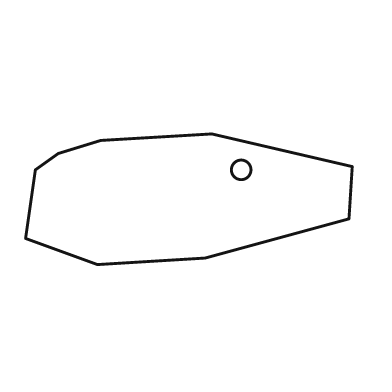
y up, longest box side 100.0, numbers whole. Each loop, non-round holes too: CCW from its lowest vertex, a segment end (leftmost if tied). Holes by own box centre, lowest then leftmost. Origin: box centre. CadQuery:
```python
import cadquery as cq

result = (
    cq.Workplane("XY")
    .moveTo(-28.0, -20.0)
    .lineTo(5.0, -18.0)
    .lineTo(49.0, -6.0)
    .lineTo(50.0, 10.0)
    .lineTo(7.0, 20.0)
    .lineTo(-27.0, 18.0)
    .lineTo(-40.0, 14.0)
    .lineTo(-47.0, 9.0)
    .lineTo(-50.0, -12.0)
    .close()
    .moveTo(16.0, 9.0)
    .circle(3.0)
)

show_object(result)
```